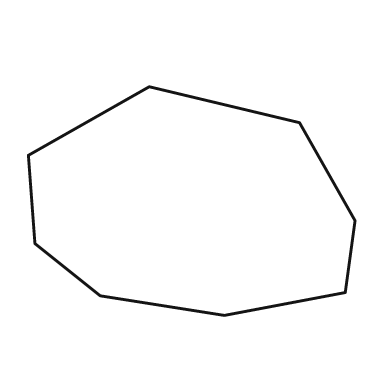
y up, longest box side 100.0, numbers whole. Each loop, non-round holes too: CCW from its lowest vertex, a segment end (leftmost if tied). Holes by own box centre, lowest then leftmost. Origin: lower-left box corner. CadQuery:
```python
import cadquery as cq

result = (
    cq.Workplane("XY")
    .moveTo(60.0, 0.0)
    .lineTo(97.0, 7.0)
    .lineTo(100.0, 29.0)
    .lineTo(83.0, 59.0)
    .lineTo(37.0, 70.0)
    .lineTo(0.0, 49.0)
    .lineTo(2.0, 22.0)
    .lineTo(22.0, 6.0)
    .close()
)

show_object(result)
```